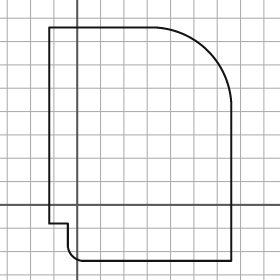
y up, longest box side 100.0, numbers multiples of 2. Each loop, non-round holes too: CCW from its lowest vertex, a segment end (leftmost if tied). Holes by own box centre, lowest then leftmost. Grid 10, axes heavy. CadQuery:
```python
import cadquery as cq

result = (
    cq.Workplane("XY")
    .moveTo(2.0, -24.0)
    .lineTo(66.0, -24.0)
    .lineTo(66.0, 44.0)
    .threePointArc((56.0, 66.0), (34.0, 76.0))
    .lineTo(-12.0, 76.0)
    .lineTo(-12.0, -8.0)
    .lineTo(-4.0, -8.0)
    .lineTo(-4.0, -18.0)
    .threePointArc((-2.0, -22.0), (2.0, -24.0))
    .close()
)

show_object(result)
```